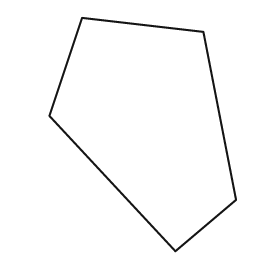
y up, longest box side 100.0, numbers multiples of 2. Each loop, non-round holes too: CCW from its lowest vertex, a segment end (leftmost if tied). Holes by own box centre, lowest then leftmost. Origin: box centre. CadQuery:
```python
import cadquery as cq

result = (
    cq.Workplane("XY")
    .moveTo(14.0, -50.0)
    .lineTo(40.0, -28.0)
    .lineTo(26.0, 44.0)
    .lineTo(-26.0, 50.0)
    .lineTo(-40.0, 8.0)
    .close()
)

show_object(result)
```